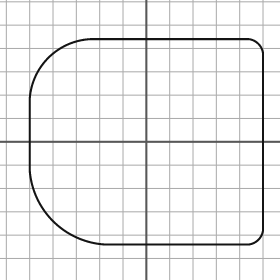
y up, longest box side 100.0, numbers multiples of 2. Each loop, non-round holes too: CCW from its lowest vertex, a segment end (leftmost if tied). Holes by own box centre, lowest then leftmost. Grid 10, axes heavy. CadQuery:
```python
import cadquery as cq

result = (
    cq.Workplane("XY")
    .moveTo(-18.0, -44.0)
    .lineTo(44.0, -44.0)
    .threePointArc((48.0, -42.0), (50.0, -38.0))
    .lineTo(50.0, 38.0)
    .threePointArc((48.0, 42.0), (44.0, 44.0))
    .lineTo(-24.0, 44.0)
    .threePointArc((-42.0, 36.0), (-50.0, 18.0))
    .lineTo(-50.0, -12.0)
    .threePointArc((-40.0, -34.0), (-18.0, -44.0))
    .close()
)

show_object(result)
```